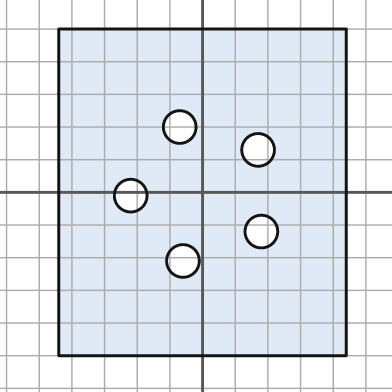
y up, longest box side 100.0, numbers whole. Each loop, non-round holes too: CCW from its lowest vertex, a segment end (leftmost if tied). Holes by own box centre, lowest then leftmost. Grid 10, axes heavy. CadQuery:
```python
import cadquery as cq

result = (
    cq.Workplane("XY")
    .moveTo(-44.0, -50.0)
    .lineTo(44.0, -50.0)
    .lineTo(44.0, 50.0)
    .lineTo(-44.0, 50.0)
    .close()
    .moveTo(-6.0, -21.0)
    .circle(5.0)
    .moveTo(18.0, -12.0)
    .circle(5.0)
    .moveTo(-22.0, -1.0)
    .circle(5.0)
    .moveTo(17.0, 13.0)
    .circle(5.0)
    .moveTo(-7.0, 20.0)
    .circle(5.0)
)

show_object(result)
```